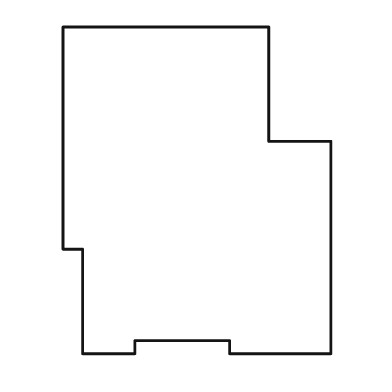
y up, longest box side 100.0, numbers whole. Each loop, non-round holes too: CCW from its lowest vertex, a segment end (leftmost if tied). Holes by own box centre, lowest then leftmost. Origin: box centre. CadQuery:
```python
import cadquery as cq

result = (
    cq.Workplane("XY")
    .moveTo(-35.0, -50.0)
    .lineTo(-19.0, -50.0)
    .lineTo(-19.0, -46.0)
    .lineTo(10.0, -46.0)
    .lineTo(10.0, -50.0)
    .lineTo(41.0, -50.0)
    .lineTo(41.0, 15.0)
    .lineTo(22.0, 15.0)
    .lineTo(22.0, 50.0)
    .lineTo(-41.0, 50.0)
    .lineTo(-41.0, -18.0)
    .lineTo(-35.0, -18.0)
    .close()
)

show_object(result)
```